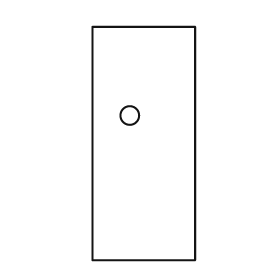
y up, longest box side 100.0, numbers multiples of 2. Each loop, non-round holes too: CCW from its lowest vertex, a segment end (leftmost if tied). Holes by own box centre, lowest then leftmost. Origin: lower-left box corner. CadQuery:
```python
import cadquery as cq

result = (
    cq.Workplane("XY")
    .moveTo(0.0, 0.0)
    .lineTo(44.0, 0.0)
    .lineTo(44.0, 100.0)
    .lineTo(0.0, 100.0)
    .close()
    .moveTo(16.0, 62.0)
    .circle(4.0)
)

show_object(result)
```